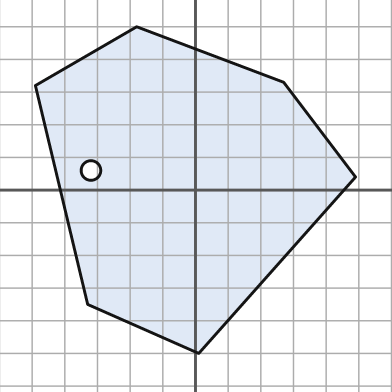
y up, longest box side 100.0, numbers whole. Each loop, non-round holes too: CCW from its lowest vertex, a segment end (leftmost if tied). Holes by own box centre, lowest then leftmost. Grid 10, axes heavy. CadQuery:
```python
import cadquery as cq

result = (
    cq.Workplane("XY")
    .moveTo(1.0, -50.0)
    .lineTo(49.0, 4.0)
    .lineTo(27.0, 33.0)
    .lineTo(-18.0, 50.0)
    .lineTo(-49.0, 32.0)
    .lineTo(-33.0, -35.0)
    .close()
    .moveTo(-32.0, 6.0)
    .circle(3.0)
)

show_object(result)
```